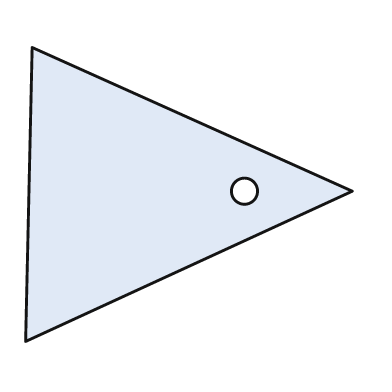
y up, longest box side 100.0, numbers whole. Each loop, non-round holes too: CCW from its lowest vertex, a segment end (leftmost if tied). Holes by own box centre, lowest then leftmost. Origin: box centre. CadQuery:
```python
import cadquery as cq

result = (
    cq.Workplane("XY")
    .moveTo(-50.0, -45.0)
    .lineTo(50.0, 1.0)
    .lineTo(-48.0, 45.0)
    .close()
    .moveTo(17.0, 1.0)
    .circle(4.0)
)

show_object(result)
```